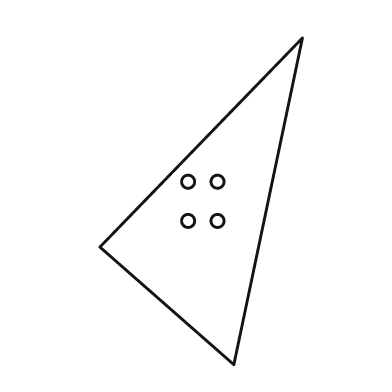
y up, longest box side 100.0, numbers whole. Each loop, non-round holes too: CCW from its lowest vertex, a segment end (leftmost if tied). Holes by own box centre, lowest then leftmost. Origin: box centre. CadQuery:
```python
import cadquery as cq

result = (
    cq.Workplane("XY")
    .moveTo(10.0, -50.0)
    .lineTo(31.0, 50.0)
    .lineTo(-31.0, -14.0)
    .close()
    .moveTo(-4.0, -6.0)
    .circle(2.0)
    .moveTo(5.0, -6.0)
    .circle(2.0)
    .moveTo(-4.0, 6.0)
    .circle(2.0)
    .moveTo(5.0, 6.0)
    .circle(2.0)
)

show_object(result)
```